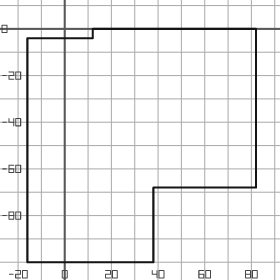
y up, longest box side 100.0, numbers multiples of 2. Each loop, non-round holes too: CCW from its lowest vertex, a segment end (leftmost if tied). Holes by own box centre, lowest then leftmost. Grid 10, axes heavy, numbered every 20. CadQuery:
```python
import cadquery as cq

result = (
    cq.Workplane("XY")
    .moveTo(-16.0, -100.0)
    .lineTo(38.0, -100.0)
    .lineTo(38.0, -68.0)
    .lineTo(82.0, -68.0)
    .lineTo(82.0, 0.0)
    .lineTo(12.0, 0.0)
    .lineTo(12.0, -4.0)
    .lineTo(-16.0, -4.0)
    .close()
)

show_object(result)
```